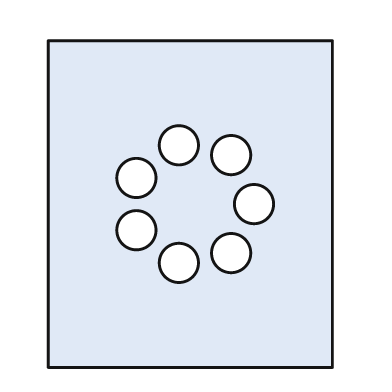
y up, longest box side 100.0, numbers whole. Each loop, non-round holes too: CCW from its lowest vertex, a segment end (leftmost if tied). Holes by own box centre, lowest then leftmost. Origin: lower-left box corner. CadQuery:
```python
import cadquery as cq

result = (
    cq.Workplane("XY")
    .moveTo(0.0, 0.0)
    .lineTo(87.0, 0.0)
    .lineTo(87.0, 100.0)
    .lineTo(0.0, 100.0)
    .close()
    .moveTo(40.0, 32.0)
    .circle(6.0)
    .moveTo(56.0, 35.0)
    .circle(6.0)
    .moveTo(27.0, 42.0)
    .circle(6.0)
    .moveTo(63.0, 50.0)
    .circle(6.0)
    .moveTo(27.0, 58.0)
    .circle(6.0)
    .moveTo(56.0, 65.0)
    .circle(6.0)
    .moveTo(40.0, 68.0)
    .circle(6.0)
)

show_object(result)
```